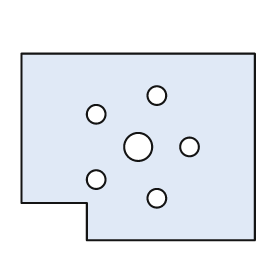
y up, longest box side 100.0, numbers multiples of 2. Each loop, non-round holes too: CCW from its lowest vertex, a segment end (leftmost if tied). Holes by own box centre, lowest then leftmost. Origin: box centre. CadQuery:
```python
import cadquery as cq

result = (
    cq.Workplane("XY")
    .moveTo(-22.0, -40.0)
    .lineTo(50.0, -40.0)
    .lineTo(50.0, 40.0)
    .lineTo(-50.0, 40.0)
    .lineTo(-50.0, -24.0)
    .lineTo(-22.0, -24.0)
    .close()
    .moveTo(8.0, -22.0)
    .circle(4.0)
    .moveTo(-18.0, -14.0)
    .circle(4.0)
    .moveTo(0.0, 0.0)
    .circle(6.0)
    .moveTo(22.0, 0.0)
    .circle(4.0)
    .moveTo(-18.0, 14.0)
    .circle(4.0)
    .moveTo(8.0, 22.0)
    .circle(4.0)
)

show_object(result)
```